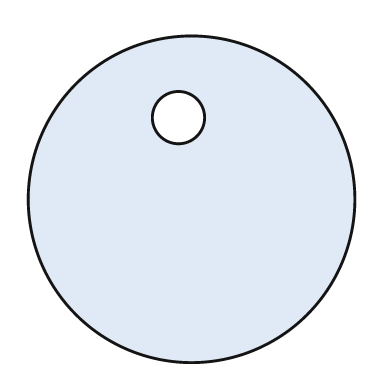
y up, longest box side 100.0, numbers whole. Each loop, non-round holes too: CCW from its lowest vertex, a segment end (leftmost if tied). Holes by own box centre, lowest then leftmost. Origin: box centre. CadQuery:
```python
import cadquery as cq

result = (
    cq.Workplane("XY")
    .moveTo(0.0, 0.0)
    .circle(50.0)
    .moveTo(-4.0, 25.0)
    .circle(8.0)
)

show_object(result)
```